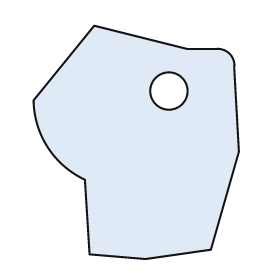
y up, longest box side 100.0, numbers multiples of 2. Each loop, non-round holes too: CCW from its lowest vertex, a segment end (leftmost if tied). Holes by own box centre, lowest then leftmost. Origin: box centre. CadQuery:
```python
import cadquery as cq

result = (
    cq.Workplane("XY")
    .moveTo(4.0, -50.0)
    .lineTo(32.0, -46.0)
    .lineTo(44.0, -4.0)
    .lineTo(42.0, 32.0)
    .threePointArc((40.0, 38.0), (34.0, 40.0))
    .lineTo(22.0, 40.0)
    .lineTo(-18.0, 50.0)
    .lineTo(-44.0, 18.0)
    .threePointArc((-38.0, -2.0), (-22.0, -16.0))
    .lineTo(-20.0, -48.0)
    .close()
    .moveTo(14.0, 22.0)
    .circle(8.0)
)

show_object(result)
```